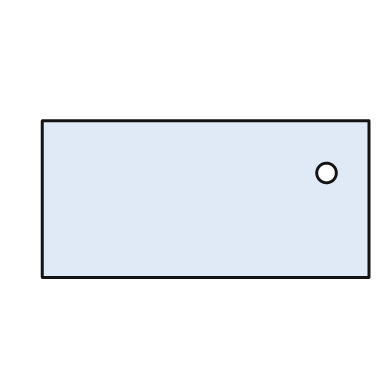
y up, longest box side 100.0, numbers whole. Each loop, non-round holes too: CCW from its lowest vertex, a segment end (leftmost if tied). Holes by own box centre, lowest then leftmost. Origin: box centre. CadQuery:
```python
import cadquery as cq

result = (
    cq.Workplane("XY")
    .moveTo(-50.0, -24.0)
    .lineTo(50.0, -24.0)
    .lineTo(50.0, 24.0)
    .lineTo(-50.0, 24.0)
    .close()
    .moveTo(37.0, 8.0)
    .circle(3.0)
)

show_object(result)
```